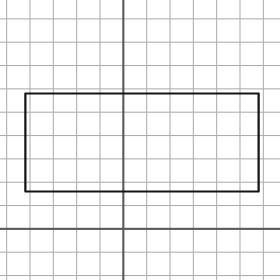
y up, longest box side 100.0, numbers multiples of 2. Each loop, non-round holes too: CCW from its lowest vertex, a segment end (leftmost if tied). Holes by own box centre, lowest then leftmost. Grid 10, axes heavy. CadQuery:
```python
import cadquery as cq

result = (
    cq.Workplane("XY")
    .moveTo(-42.0, 16.0)
    .lineTo(58.0, 16.0)
    .lineTo(58.0, 58.0)
    .lineTo(-42.0, 58.0)
    .close()
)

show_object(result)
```